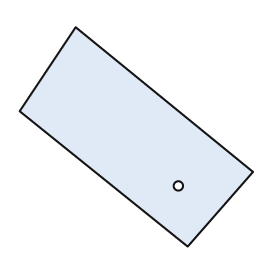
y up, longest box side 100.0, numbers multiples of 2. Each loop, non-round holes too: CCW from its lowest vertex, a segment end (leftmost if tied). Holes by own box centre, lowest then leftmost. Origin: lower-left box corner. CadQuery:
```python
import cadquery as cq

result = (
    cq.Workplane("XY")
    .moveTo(72.0, 0.0)
    .lineTo(100.0, 32.0)
    .lineTo(24.0, 94.0)
    .lineTo(0.0, 58.0)
    .close()
    .moveTo(68.0, 26.0)
    .circle(2.0)
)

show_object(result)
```